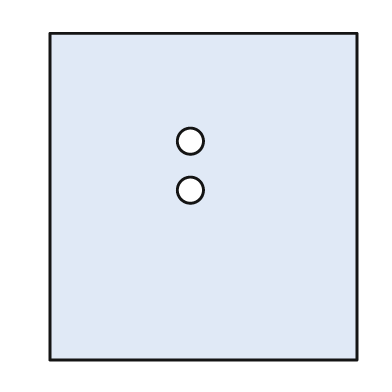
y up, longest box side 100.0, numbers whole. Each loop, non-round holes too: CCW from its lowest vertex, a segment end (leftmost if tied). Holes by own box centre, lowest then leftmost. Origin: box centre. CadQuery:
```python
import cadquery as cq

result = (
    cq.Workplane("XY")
    .moveTo(-47.0, -50.0)
    .lineTo(47.0, -50.0)
    .lineTo(47.0, 50.0)
    .lineTo(-47.0, 50.0)
    .close()
    .moveTo(-4.0, 2.0)
    .circle(4.0)
    .moveTo(-4.0, 17.0)
    .circle(4.0)
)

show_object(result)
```